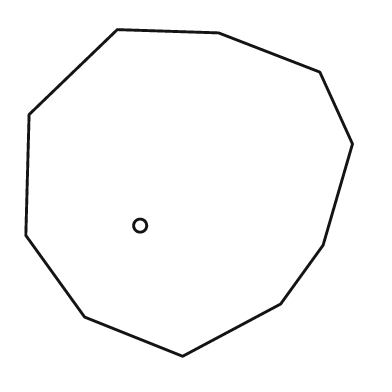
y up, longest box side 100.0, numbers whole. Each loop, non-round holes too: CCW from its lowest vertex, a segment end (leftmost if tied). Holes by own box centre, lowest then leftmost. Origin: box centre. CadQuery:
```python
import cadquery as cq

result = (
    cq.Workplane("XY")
    .moveTo(-2.0, -50.0)
    .lineTo(28.0, -34.0)
    .lineTo(41.0, -16.0)
    .lineTo(50.0, 15.0)
    .lineTo(40.0, 37.0)
    .lineTo(9.0, 49.0)
    .lineTo(-22.0, 50.0)
    .lineTo(-49.0, 24.0)
    .lineTo(-50.0, -13.0)
    .lineTo(-32.0, -38.0)
    .close()
    .moveTo(-15.0, -10.0)
    .circle(2.0)
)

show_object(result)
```